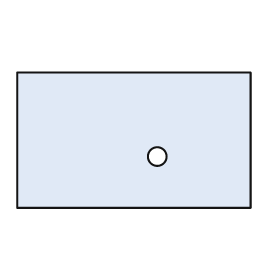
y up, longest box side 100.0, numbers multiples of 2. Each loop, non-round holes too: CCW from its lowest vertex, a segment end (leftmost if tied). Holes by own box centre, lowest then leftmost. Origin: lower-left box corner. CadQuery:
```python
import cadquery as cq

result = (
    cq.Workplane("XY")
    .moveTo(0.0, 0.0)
    .lineTo(100.0, 0.0)
    .lineTo(100.0, 58.0)
    .lineTo(0.0, 58.0)
    .close()
    .moveTo(60.0, 22.0)
    .circle(4.0)
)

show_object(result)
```